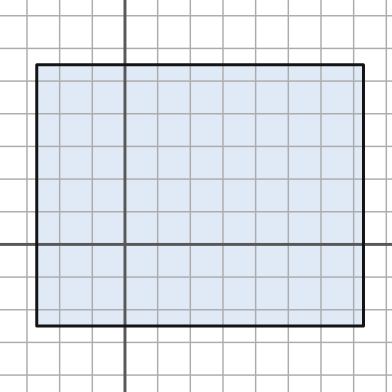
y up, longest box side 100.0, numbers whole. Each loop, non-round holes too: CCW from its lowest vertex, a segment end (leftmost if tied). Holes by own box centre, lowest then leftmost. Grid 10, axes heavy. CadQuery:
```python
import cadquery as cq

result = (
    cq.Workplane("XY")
    .moveTo(-27.0, -25.0)
    .lineTo(73.0, -25.0)
    .lineTo(73.0, 55.0)
    .lineTo(-27.0, 55.0)
    .close()
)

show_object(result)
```